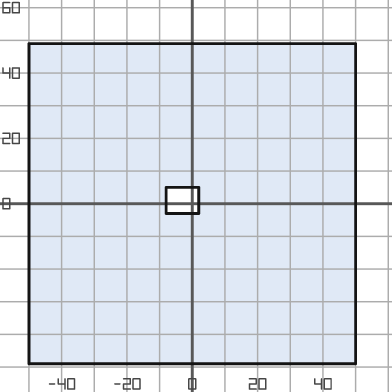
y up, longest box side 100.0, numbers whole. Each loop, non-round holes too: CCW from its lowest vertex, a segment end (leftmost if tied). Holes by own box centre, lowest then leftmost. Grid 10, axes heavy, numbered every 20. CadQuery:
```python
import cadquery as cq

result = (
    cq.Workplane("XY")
    .moveTo(-50.0, -49.0)
    .lineTo(50.0, -49.0)
    .lineTo(50.0, 49.0)
    .lineTo(-50.0, 49.0)
    .close()
    .moveTo(-8.0, -3.0)
    .lineTo(2.0, -3.0)
    .lineTo(2.0, 5.0)
    .lineTo(-8.0, 5.0)
    .close()
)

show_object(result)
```